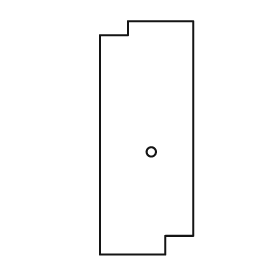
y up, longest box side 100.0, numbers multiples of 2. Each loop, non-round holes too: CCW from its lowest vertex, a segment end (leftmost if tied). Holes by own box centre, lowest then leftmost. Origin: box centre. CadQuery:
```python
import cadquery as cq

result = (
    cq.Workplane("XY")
    .moveTo(-20.0, -50.0)
    .lineTo(8.0, -50.0)
    .lineTo(8.0, -42.0)
    .lineTo(20.0, -42.0)
    .lineTo(20.0, 50.0)
    .lineTo(-8.0, 50.0)
    .lineTo(-8.0, 44.0)
    .lineTo(-20.0, 44.0)
    .close()
    .moveTo(2.0, -6.0)
    .circle(2.0)
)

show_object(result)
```